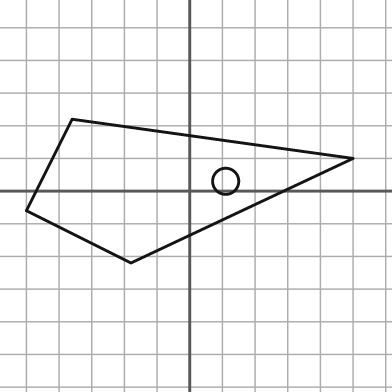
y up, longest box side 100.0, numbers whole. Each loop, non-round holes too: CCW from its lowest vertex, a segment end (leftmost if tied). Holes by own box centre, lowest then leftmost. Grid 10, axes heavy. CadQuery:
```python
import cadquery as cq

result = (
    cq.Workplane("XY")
    .moveTo(-18.0, -22.0)
    .lineTo(50.0, 10.0)
    .lineTo(-36.0, 22.0)
    .lineTo(-50.0, -6.0)
    .close()
    .moveTo(11.0, 3.0)
    .circle(4.0)
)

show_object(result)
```